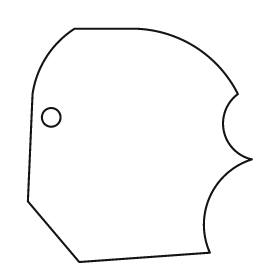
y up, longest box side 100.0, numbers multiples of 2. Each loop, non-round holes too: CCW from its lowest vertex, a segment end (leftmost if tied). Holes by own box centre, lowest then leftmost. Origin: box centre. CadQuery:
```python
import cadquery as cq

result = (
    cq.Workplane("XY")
    .moveTo(-26.0, -50.0)
    .lineTo(30.0, -46.0)
    .threePointArc((30.0, -22.0), (48.0, -6.0))
    .threePointArc((36.0, 6.0), (42.0, 22.0))
    .threePointArc((24.0, 42.0), (-2.0, 50.0))
    .lineTo(-28.0, 50.0)
    .threePointArc((-40.0, 38.0), (-46.0, 22.0))
    .lineTo(-48.0, -24.0)
    .close()
    .moveTo(-38.0, 12.0)
    .circle(4.0)
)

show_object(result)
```